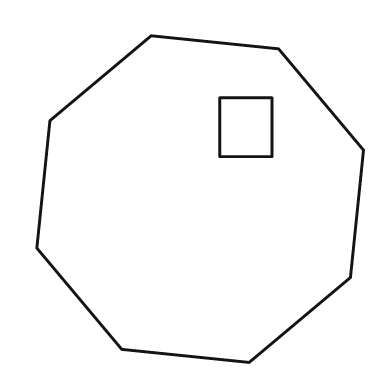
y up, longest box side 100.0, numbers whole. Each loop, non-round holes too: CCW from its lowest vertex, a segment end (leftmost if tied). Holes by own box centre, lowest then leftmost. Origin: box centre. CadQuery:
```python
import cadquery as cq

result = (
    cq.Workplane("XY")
    .moveTo(15.0, -50.0)
    .lineTo(46.0, -24.0)
    .lineTo(50.0, 15.0)
    .lineTo(24.0, 46.0)
    .lineTo(-15.0, 50.0)
    .lineTo(-46.0, 24.0)
    .lineTo(-50.0, -15.0)
    .lineTo(-24.0, -46.0)
    .close()
    .moveTo(6.0, 13.0)
    .lineTo(22.0, 13.0)
    .lineTo(22.0, 31.0)
    .lineTo(6.0, 31.0)
    .close()
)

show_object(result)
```